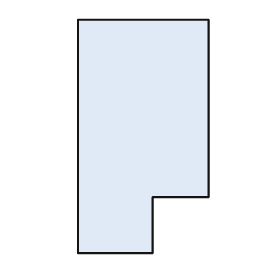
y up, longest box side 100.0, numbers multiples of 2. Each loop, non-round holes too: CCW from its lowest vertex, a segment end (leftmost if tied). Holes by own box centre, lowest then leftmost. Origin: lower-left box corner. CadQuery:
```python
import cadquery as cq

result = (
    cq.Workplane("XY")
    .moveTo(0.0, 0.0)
    .lineTo(32.0, 0.0)
    .lineTo(32.0, 24.0)
    .lineTo(56.0, 24.0)
    .lineTo(56.0, 100.0)
    .lineTo(0.0, 100.0)
    .close()
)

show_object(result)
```